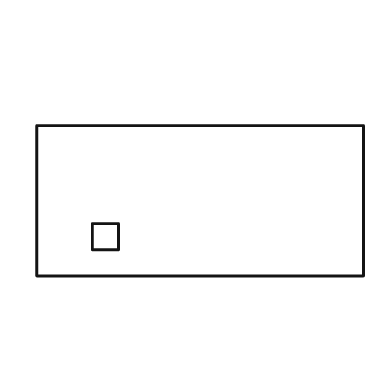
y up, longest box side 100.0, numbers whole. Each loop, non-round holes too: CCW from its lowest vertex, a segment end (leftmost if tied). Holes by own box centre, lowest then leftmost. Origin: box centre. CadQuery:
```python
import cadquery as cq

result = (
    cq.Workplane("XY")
    .moveTo(-50.0, -23.0)
    .lineTo(50.0, -23.0)
    .lineTo(50.0, 23.0)
    .lineTo(-50.0, 23.0)
    .close()
    .moveTo(-33.0, -15.0)
    .lineTo(-25.0, -15.0)
    .lineTo(-25.0, -7.0)
    .lineTo(-33.0, -7.0)
    .close()
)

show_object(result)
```